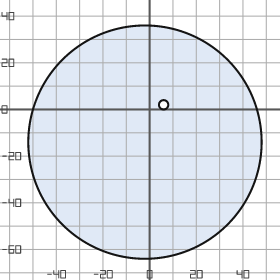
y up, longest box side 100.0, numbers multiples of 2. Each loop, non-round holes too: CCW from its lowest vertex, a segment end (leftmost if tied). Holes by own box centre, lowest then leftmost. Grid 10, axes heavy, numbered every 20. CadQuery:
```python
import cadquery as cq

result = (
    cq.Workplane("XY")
    .moveTo(-2.0, -14.0)
    .circle(50.0)
    .moveTo(6.0, 2.0)
    .circle(2.0)
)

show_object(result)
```